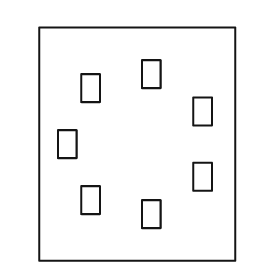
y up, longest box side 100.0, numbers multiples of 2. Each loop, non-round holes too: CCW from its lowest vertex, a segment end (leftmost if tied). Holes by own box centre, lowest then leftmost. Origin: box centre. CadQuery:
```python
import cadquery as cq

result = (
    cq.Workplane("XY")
    .moveTo(-42.0, -50.0)
    .lineTo(42.0, -50.0)
    .lineTo(42.0, 50.0)
    .lineTo(-42.0, 50.0)
    .close()
    .moveTo(2.0, -36.0)
    .lineTo(10.0, -36.0)
    .lineTo(10.0, -24.0)
    .lineTo(2.0, -24.0)
    .close()
    .moveTo(-24.0, -30.0)
    .lineTo(-16.0, -30.0)
    .lineTo(-16.0, -18.0)
    .lineTo(-24.0, -18.0)
    .close()
    .moveTo(24.0, -20.0)
    .lineTo(32.0, -20.0)
    .lineTo(32.0, -8.0)
    .lineTo(24.0, -8.0)
    .close()
    .moveTo(-34.0, -6.0)
    .lineTo(-26.0, -6.0)
    .lineTo(-26.0, 6.0)
    .lineTo(-34.0, 6.0)
    .close()
    .moveTo(24.0, 8.0)
    .lineTo(32.0, 8.0)
    .lineTo(32.0, 20.0)
    .lineTo(24.0, 20.0)
    .close()
    .moveTo(-24.0, 18.0)
    .lineTo(-16.0, 18.0)
    .lineTo(-16.0, 30.0)
    .lineTo(-24.0, 30.0)
    .close()
    .moveTo(2.0, 24.0)
    .lineTo(10.0, 24.0)
    .lineTo(10.0, 36.0)
    .lineTo(2.0, 36.0)
    .close()
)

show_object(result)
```